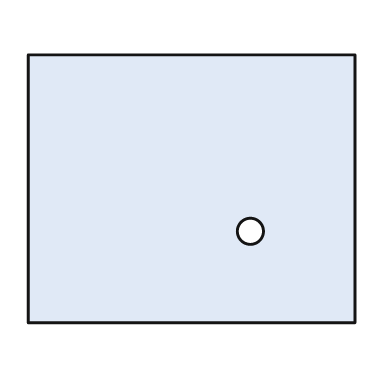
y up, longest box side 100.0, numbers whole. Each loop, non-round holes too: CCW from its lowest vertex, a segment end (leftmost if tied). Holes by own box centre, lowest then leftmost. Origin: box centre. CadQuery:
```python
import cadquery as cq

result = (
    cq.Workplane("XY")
    .moveTo(-50.0, -41.0)
    .lineTo(50.0, -41.0)
    .lineTo(50.0, 41.0)
    .lineTo(-50.0, 41.0)
    .close()
    .moveTo(18.0, -13.0)
    .circle(4.0)
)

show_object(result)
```